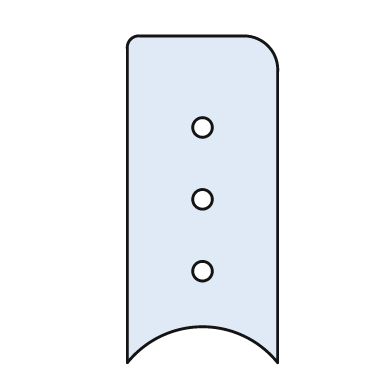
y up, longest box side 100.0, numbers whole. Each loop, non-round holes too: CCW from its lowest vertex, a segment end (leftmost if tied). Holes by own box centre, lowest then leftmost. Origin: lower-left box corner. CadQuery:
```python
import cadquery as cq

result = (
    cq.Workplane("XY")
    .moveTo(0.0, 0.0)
    .threePointArc((23.0, 11.0), (46.0, 0.0))
    .lineTo(46.0, 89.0)
    .threePointArc((43.0, 97.0), (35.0, 100.0))
    .lineTo(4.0, 100.0)
    .threePointArc((1.0, 99.0), (0.0, 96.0))
    .close()
    .moveTo(23.0, 28.0)
    .circle(3.0)
    .moveTo(23.0, 50.0)
    .circle(3.0)
    .moveTo(23.0, 72.0)
    .circle(3.0)
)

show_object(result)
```